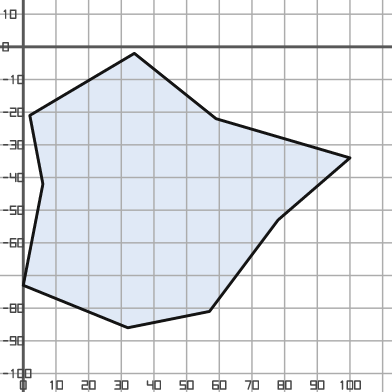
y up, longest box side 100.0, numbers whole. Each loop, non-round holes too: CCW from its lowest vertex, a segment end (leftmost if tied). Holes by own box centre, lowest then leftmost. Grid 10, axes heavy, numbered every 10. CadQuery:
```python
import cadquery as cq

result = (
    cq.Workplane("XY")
    .moveTo(32.0, -86.0)
    .lineTo(57.0, -81.0)
    .lineTo(78.0, -53.0)
    .lineTo(100.0, -34.0)
    .lineTo(59.0, -22.0)
    .lineTo(34.0, -2.0)
    .lineTo(2.0, -21.0)
    .lineTo(6.0, -42.0)
    .lineTo(0.0, -73.0)
    .close()
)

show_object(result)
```